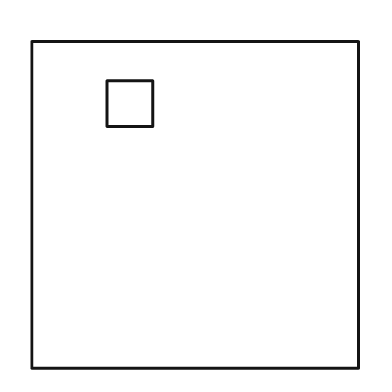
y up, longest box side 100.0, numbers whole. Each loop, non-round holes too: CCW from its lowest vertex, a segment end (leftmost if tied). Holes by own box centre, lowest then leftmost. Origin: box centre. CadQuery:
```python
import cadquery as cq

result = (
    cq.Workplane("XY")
    .moveTo(-50.0, -50.0)
    .lineTo(50.0, -50.0)
    .lineTo(50.0, 50.0)
    .lineTo(-50.0, 50.0)
    .close()
    .moveTo(-27.0, 24.0)
    .lineTo(-13.0, 24.0)
    .lineTo(-13.0, 38.0)
    .lineTo(-27.0, 38.0)
    .close()
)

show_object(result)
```